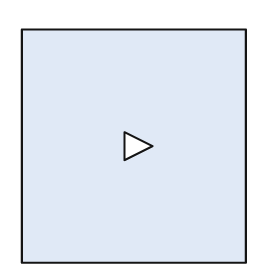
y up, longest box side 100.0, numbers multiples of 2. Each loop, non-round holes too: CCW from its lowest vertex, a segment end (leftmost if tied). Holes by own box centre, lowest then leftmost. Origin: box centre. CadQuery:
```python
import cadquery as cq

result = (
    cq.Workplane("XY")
    .moveTo(-48.0, -50.0)
    .lineTo(48.0, -50.0)
    .lineTo(48.0, 50.0)
    .lineTo(-48.0, 50.0)
    .close()
    .moveTo(-4.0, -6.0)
    .lineTo(8.0, 0.0)
    .lineTo(-4.0, 6.0)
    .close()
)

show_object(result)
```